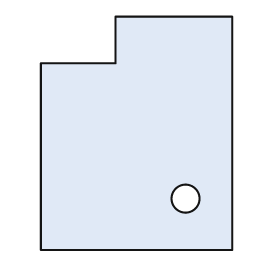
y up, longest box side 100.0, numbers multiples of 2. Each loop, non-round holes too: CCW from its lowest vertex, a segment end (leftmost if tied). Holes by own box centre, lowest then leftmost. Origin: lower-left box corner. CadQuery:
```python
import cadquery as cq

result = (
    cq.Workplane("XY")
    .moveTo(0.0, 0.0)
    .lineTo(82.0, 0.0)
    .lineTo(82.0, 100.0)
    .lineTo(32.0, 100.0)
    .lineTo(32.0, 80.0)
    .lineTo(0.0, 80.0)
    .close()
    .moveTo(62.0, 22.0)
    .circle(6.0)
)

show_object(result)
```